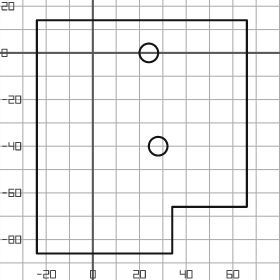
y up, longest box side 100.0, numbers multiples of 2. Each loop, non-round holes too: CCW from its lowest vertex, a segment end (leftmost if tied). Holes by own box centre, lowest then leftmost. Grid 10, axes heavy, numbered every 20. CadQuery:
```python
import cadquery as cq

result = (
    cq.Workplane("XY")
    .moveTo(-24.0, -86.0)
    .lineTo(34.0, -86.0)
    .lineTo(34.0, -66.0)
    .lineTo(66.0, -66.0)
    .lineTo(66.0, 14.0)
    .lineTo(-24.0, 14.0)
    .close()
    .moveTo(28.0, -40.0)
    .circle(4.0)
    .moveTo(24.0, 0.0)
    .circle(4.0)
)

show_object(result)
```